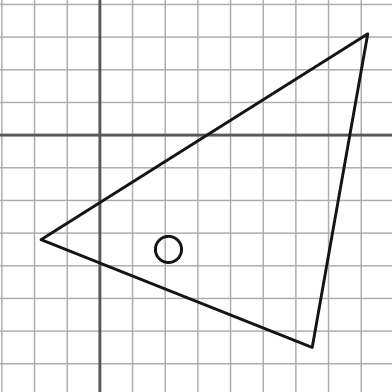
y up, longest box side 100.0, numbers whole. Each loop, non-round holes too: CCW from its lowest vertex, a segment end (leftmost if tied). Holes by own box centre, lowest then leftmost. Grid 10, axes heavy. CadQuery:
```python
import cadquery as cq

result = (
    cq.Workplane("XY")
    .moveTo(65.0, -65.0)
    .lineTo(82.0, 31.0)
    .lineTo(-18.0, -32.0)
    .close()
    .moveTo(21.0, -35.0)
    .circle(4.0)
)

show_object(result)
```